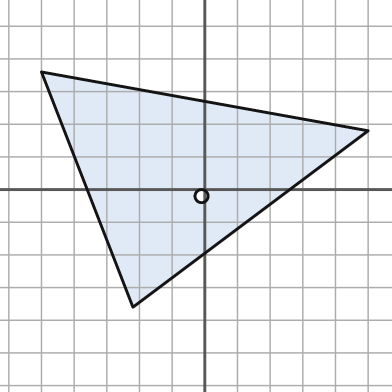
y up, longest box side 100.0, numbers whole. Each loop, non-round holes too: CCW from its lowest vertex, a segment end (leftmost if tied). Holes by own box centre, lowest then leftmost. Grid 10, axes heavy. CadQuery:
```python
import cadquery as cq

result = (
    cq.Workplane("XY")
    .moveTo(-22.0, -36.0)
    .lineTo(50.0, 18.0)
    .lineTo(-50.0, 36.0)
    .close()
    .moveTo(-1.0, -2.0)
    .circle(2.0)
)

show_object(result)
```